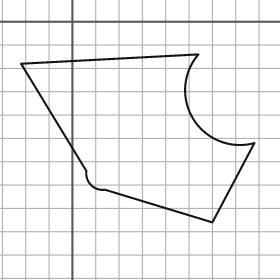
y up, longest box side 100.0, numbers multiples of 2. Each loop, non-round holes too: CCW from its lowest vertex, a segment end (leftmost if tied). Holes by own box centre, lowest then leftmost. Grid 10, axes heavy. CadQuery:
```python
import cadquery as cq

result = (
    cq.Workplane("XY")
    .moveTo(60.0, -86.0)
    .lineTo(78.0, -52.0)
    .threePointArc((52.0, -42.0), (54.0, -14.0))
    .lineTo(-22.0, -18.0)
    .lineTo(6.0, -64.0)
    .threePointArc((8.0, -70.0), (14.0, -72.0))
    .close()
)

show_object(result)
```